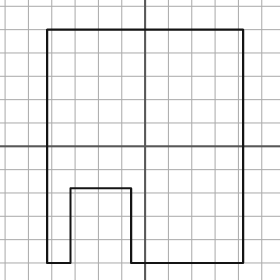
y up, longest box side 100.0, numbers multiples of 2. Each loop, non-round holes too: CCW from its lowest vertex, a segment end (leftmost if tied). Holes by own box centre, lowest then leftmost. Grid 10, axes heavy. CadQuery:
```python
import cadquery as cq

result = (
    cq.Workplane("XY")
    .moveTo(-42.0, -50.0)
    .lineTo(-32.0, -50.0)
    .lineTo(-32.0, -18.0)
    .lineTo(-6.0, -18.0)
    .lineTo(-6.0, -50.0)
    .lineTo(42.0, -50.0)
    .lineTo(42.0, 50.0)
    .lineTo(-42.0, 50.0)
    .close()
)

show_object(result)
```